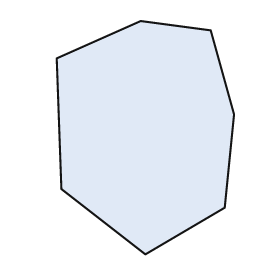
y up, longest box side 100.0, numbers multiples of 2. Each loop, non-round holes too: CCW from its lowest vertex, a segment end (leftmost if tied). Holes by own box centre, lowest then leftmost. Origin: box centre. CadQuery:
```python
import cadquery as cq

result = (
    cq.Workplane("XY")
    .moveTo(0.0, -50.0)
    .lineTo(34.0, -30.0)
    .lineTo(38.0, 10.0)
    .lineTo(28.0, 46.0)
    .lineTo(-2.0, 50.0)
    .lineTo(-38.0, 34.0)
    .lineTo(-36.0, -22.0)
    .close()
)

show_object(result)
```